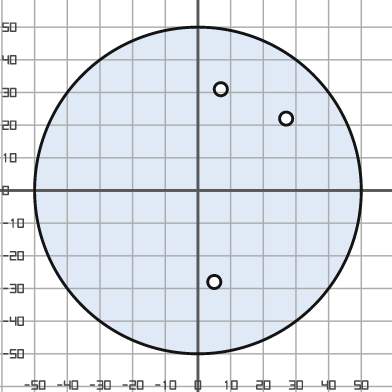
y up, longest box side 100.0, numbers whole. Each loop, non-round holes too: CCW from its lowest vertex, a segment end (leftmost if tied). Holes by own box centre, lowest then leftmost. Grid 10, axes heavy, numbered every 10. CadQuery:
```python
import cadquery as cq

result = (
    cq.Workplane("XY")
    .moveTo(0.0, 0.0)
    .circle(50.0)
    .moveTo(5.0, -28.0)
    .circle(2.0)
    .moveTo(27.0, 22.0)
    .circle(2.0)
    .moveTo(7.0, 31.0)
    .circle(2.0)
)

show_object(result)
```